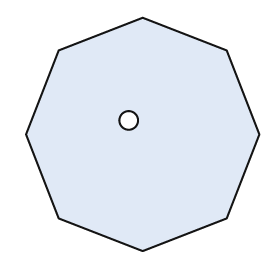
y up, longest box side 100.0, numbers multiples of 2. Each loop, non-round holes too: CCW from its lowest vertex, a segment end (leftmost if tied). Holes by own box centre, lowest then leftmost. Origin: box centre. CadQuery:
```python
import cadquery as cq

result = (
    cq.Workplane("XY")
    .moveTo(0.0, -50.0)
    .lineTo(36.0, -36.0)
    .lineTo(50.0, 0.0)
    .lineTo(36.0, 36.0)
    .lineTo(0.0, 50.0)
    .lineTo(-36.0, 36.0)
    .lineTo(-50.0, 0.0)
    .lineTo(-36.0, -36.0)
    .close()
    .moveTo(-6.0, 6.0)
    .circle(4.0)
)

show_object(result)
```